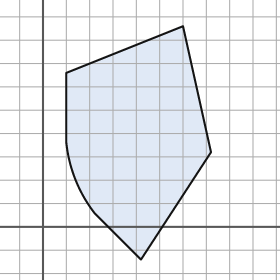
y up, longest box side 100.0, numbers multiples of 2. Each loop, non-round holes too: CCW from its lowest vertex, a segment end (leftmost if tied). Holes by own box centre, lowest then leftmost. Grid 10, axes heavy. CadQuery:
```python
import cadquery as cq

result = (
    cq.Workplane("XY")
    .moveTo(42.0, -14.0)
    .lineTo(72.0, 32.0)
    .lineTo(60.0, 86.0)
    .lineTo(10.0, 66.0)
    .lineTo(10.0, 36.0)
    .threePointArc((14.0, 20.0), (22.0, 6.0))
    .close()
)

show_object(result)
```